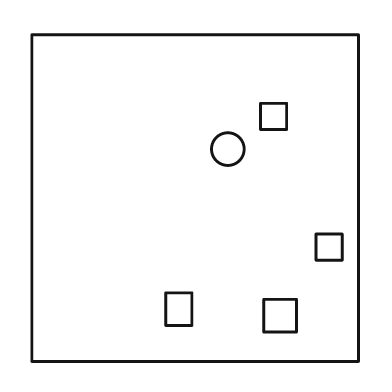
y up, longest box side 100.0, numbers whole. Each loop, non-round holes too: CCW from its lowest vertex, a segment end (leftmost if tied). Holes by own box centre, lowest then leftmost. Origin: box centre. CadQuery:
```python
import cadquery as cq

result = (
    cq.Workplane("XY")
    .moveTo(-50.0, -50.0)
    .lineTo(50.0, -50.0)
    .lineTo(50.0, 50.0)
    .lineTo(-50.0, 50.0)
    .close()
    .moveTo(21.0, -41.0)
    .lineTo(31.0, -41.0)
    .lineTo(31.0, -31.0)
    .lineTo(21.0, -31.0)
    .close()
    .moveTo(-9.0, -39.0)
    .lineTo(-1.0, -39.0)
    .lineTo(-1.0, -29.0)
    .lineTo(-9.0, -29.0)
    .close()
    .moveTo(37.0, -19.0)
    .lineTo(45.0, -19.0)
    .lineTo(45.0, -11.0)
    .lineTo(37.0, -11.0)
    .close()
    .moveTo(10.0, 15.0)
    .circle(5.0)
    .moveTo(20.0, 21.0)
    .lineTo(28.0, 21.0)
    .lineTo(28.0, 29.0)
    .lineTo(20.0, 29.0)
    .close()
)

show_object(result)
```